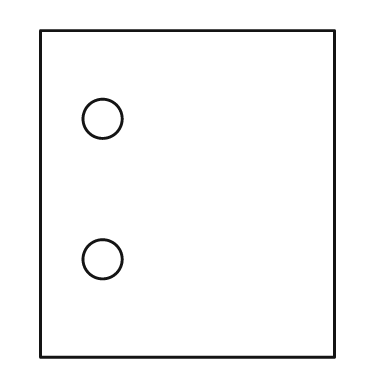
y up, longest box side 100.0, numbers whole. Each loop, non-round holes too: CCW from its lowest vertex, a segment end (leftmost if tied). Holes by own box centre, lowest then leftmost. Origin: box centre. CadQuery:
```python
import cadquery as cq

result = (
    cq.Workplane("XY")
    .moveTo(-45.0, -50.0)
    .lineTo(45.0, -50.0)
    .lineTo(45.0, 50.0)
    .lineTo(-45.0, 50.0)
    .close()
    .moveTo(-26.0, -20.0)
    .circle(6.0)
    .moveTo(-26.0, 23.0)
    .circle(6.0)
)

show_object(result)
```